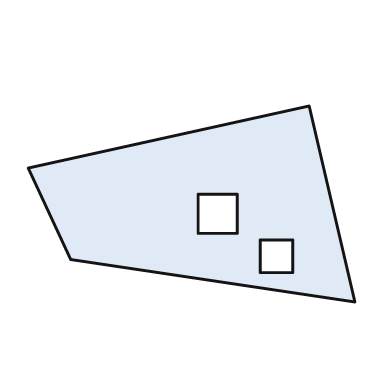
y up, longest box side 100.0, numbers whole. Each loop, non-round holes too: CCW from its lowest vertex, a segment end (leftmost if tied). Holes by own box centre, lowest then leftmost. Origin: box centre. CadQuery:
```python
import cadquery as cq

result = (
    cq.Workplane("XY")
    .moveTo(50.0, -30.0)
    .lineTo(36.0, 30.0)
    .lineTo(-50.0, 11.0)
    .lineTo(-37.0, -17.0)
    .close()
    .moveTo(21.0, -21.0)
    .lineTo(31.0, -21.0)
    .lineTo(31.0, -11.0)
    .lineTo(21.0, -11.0)
    .close()
    .moveTo(2.0, -9.0)
    .lineTo(14.0, -9.0)
    .lineTo(14.0, 3.0)
    .lineTo(2.0, 3.0)
    .close()
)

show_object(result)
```